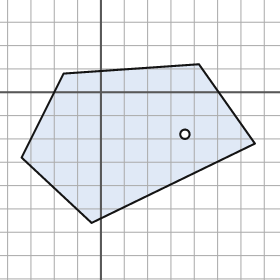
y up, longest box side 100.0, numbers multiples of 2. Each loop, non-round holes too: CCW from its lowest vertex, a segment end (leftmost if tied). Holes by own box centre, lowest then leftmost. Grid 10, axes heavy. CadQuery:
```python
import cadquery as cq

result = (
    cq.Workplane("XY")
    .moveTo(-4.0, -56.0)
    .lineTo(66.0, -22.0)
    .lineTo(42.0, 12.0)
    .lineTo(-16.0, 8.0)
    .lineTo(-34.0, -28.0)
    .close()
    .moveTo(36.0, -18.0)
    .circle(2.0)
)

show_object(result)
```